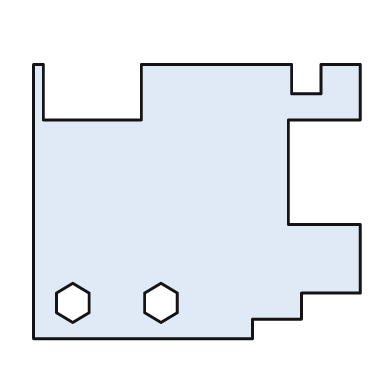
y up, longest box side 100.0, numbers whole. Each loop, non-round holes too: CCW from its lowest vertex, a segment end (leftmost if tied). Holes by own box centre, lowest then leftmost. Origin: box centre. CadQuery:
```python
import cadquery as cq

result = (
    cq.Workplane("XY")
    .moveTo(-50.0, -42.0)
    .lineTo(17.0, -42.0)
    .lineTo(17.0, -36.0)
    .lineTo(32.0, -36.0)
    .lineTo(32.0, -28.0)
    .lineTo(50.0, -28.0)
    .lineTo(50.0, -7.0)
    .lineTo(28.0, -7.0)
    .lineTo(28.0, 25.0)
    .lineTo(50.0, 25.0)
    .lineTo(50.0, 42.0)
    .lineTo(38.0, 42.0)
    .lineTo(38.0, 33.0)
    .lineTo(29.0, 33.0)
    .lineTo(29.0, 42.0)
    .lineTo(-17.0, 42.0)
    .lineTo(-17.0, 25.0)
    .lineTo(-47.0, 25.0)
    .lineTo(-47.0, 42.0)
    .lineTo(-50.0, 42.0)
    .close()
    .moveTo(-38.0, -37.0)
    .lineTo(-33.0, -34.0)
    .lineTo(-33.0, -28.0)
    .lineTo(-38.0, -25.0)
    .lineTo(-43.0, -28.0)
    .lineTo(-43.0, -34.0)
    .close()
    .moveTo(-11.0, -37.0)
    .lineTo(-6.0, -34.0)
    .lineTo(-6.0, -28.0)
    .lineTo(-11.0, -25.0)
    .lineTo(-16.0, -28.0)
    .lineTo(-16.0, -34.0)
    .close()
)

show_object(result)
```